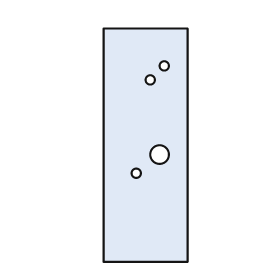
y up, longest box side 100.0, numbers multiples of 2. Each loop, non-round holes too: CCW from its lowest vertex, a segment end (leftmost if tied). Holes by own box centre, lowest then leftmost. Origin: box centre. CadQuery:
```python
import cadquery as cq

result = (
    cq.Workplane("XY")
    .moveTo(-18.0, -50.0)
    .lineTo(18.0, -50.0)
    .lineTo(18.0, 50.0)
    .lineTo(-18.0, 50.0)
    .close()
    .moveTo(-4.0, -12.0)
    .circle(2.0)
    .moveTo(6.0, -4.0)
    .circle(4.0)
    .moveTo(2.0, 28.0)
    .circle(2.0)
    .moveTo(8.0, 34.0)
    .circle(2.0)
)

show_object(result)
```